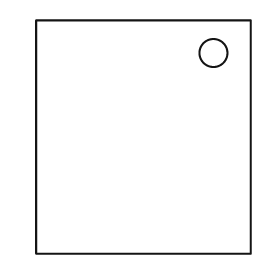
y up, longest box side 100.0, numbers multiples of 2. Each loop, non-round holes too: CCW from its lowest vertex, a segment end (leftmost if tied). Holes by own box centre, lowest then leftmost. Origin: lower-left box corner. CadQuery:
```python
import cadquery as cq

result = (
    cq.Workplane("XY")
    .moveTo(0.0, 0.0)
    .lineTo(92.0, 0.0)
    .lineTo(92.0, 100.0)
    .lineTo(0.0, 100.0)
    .close()
    .moveTo(76.0, 86.0)
    .circle(6.0)
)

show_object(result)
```